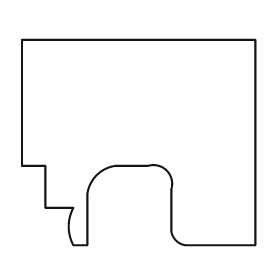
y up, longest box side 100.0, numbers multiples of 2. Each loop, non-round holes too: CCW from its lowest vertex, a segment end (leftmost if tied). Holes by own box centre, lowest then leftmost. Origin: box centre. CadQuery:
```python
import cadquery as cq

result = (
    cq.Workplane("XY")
    .moveTo(-28.0, -44.0)
    .lineTo(-22.0, -44.0)
    .lineTo(-22.0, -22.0)
    .threePointArc((-18.0, -14.0), (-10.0, -10.0))
    .lineTo(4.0, -10.0)
    .threePointArc((12.0, -12.0), (14.0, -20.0))
    .lineTo(14.0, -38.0)
    .threePointArc((16.0, -42.0), (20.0, -44.0))
    .lineTo(50.0, -44.0)
    .lineTo(50.0, 44.0)
    .lineTo(-50.0, 44.0)
    .lineTo(-50.0, -10.0)
    .lineTo(-40.0, -10.0)
    .lineTo(-40.0, -28.0)
    .lineTo(-28.0, -28.0)
    .threePointArc((-30.0, -36.0), (-28.0, -44.0))
    .close()
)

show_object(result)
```